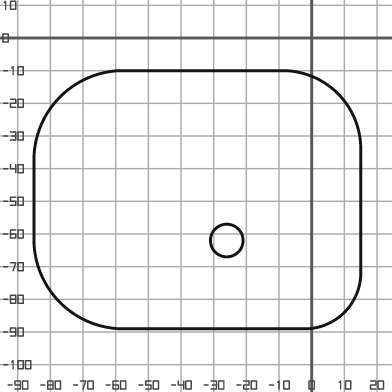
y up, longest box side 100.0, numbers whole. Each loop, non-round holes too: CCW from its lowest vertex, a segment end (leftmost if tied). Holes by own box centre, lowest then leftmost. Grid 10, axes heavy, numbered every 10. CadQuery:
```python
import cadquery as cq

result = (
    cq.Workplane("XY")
    .moveTo(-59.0, -89.0)
    .lineTo(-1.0, -89.0)
    .threePointArc((10.0, -84.0), (15.0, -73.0))
    .lineTo(15.0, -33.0)
    .threePointArc((8.0, -17.0), (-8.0, -10.0))
    .lineTo(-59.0, -10.0)
    .threePointArc((-77.0, -18.0), (-85.0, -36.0))
    .lineTo(-85.0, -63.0)
    .threePointArc((-77.0, -81.0), (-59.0, -89.0))
    .close()
    .moveTo(-26.0, -62.0)
    .circle(5.0)
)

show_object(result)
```